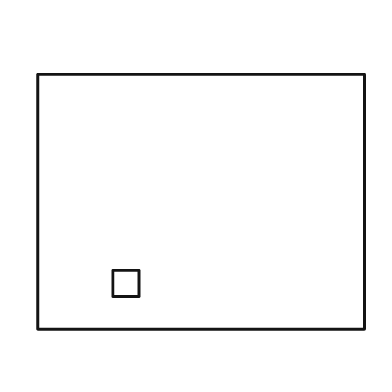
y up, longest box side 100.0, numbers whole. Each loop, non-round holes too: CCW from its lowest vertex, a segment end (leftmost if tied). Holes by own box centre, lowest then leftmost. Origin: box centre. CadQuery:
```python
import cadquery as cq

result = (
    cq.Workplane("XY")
    .moveTo(-50.0, -39.0)
    .lineTo(50.0, -39.0)
    .lineTo(50.0, 39.0)
    .lineTo(-50.0, 39.0)
    .close()
    .moveTo(-27.0, -29.0)
    .lineTo(-19.0, -29.0)
    .lineTo(-19.0, -21.0)
    .lineTo(-27.0, -21.0)
    .close()
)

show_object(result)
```